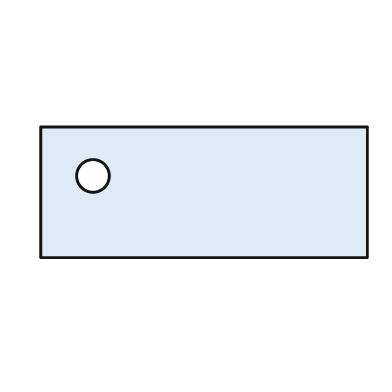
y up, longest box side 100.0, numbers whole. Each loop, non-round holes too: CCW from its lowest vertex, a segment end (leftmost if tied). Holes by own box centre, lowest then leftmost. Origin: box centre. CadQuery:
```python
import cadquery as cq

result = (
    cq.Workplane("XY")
    .moveTo(-50.0, -20.0)
    .lineTo(50.0, -20.0)
    .lineTo(50.0, 20.0)
    .lineTo(-50.0, 20.0)
    .close()
    .moveTo(-34.0, 5.0)
    .circle(5.0)
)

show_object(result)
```